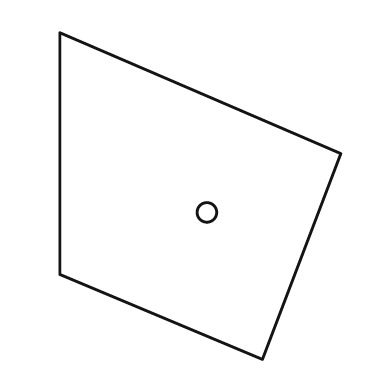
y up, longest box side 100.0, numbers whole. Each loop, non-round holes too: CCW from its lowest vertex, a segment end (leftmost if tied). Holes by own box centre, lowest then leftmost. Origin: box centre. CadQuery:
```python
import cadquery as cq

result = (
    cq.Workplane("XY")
    .moveTo(19.0, -50.0)
    .lineTo(43.0, 13.0)
    .lineTo(-43.0, 50.0)
    .lineTo(-43.0, -24.0)
    .close()
    .moveTo(2.0, -5.0)
    .circle(3.0)
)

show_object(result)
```